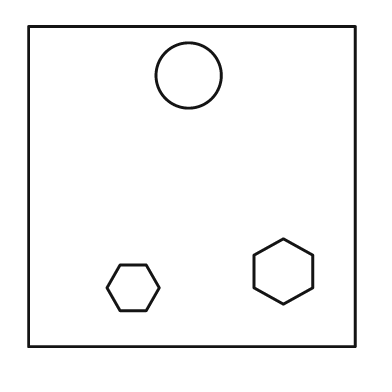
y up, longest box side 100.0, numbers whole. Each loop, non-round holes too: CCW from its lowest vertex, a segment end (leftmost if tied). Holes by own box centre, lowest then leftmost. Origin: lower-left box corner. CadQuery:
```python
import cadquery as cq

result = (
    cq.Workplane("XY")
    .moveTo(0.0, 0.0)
    .lineTo(100.0, 0.0)
    .lineTo(100.0, 98.0)
    .lineTo(0.0, 98.0)
    .close()
    .moveTo(28.0, 11.0)
    .lineTo(36.0, 11.0)
    .lineTo(40.0, 18.0)
    .lineTo(36.0, 25.0)
    .lineTo(28.0, 25.0)
    .lineTo(24.0, 18.0)
    .close()
    .moveTo(78.0, 13.0)
    .lineTo(87.0, 18.0)
    .lineTo(87.0, 28.0)
    .lineTo(78.0, 33.0)
    .lineTo(69.0, 28.0)
    .lineTo(69.0, 18.0)
    .close()
    .moveTo(49.0, 83.0)
    .circle(10.0)
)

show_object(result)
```